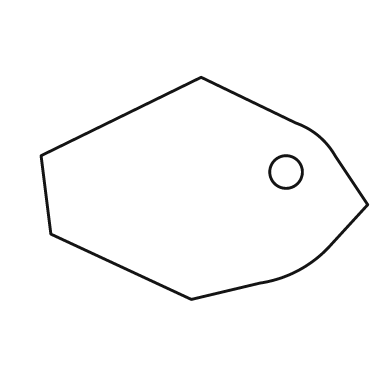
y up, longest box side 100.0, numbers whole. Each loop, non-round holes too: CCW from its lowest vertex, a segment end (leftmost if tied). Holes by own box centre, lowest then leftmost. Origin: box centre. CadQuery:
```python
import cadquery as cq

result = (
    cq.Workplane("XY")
    .moveTo(-4.0, -34.0)
    .lineTo(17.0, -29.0)
    .threePointArc((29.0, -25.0), (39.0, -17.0))
    .lineTo(50.0, -5.0)
    .lineTo(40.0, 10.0)
    .threePointArc((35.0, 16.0), (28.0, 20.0))
    .lineTo(-1.0, 34.0)
    .lineTo(-50.0, 10.0)
    .lineTo(-47.0, -14.0)
    .close()
    .moveTo(25.0, 5.0)
    .circle(5.0)
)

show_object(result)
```